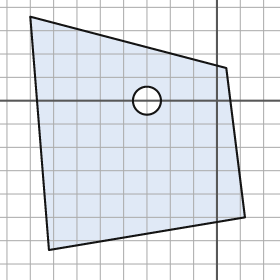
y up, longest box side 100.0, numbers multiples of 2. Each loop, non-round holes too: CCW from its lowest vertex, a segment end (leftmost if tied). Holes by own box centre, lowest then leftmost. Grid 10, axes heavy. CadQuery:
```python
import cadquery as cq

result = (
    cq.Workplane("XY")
    .moveTo(-72.0, -64.0)
    .lineTo(12.0, -50.0)
    .lineTo(4.0, 14.0)
    .lineTo(-80.0, 36.0)
    .close()
    .moveTo(-30.0, 0.0)
    .circle(6.0)
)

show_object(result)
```